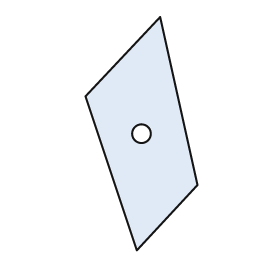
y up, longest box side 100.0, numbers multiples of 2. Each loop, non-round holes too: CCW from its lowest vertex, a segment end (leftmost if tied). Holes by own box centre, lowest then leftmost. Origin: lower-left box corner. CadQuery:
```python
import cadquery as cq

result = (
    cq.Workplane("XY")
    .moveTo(22.0, 0.0)
    .lineTo(48.0, 28.0)
    .lineTo(32.0, 100.0)
    .lineTo(0.0, 66.0)
    .close()
    .moveTo(24.0, 50.0)
    .circle(4.0)
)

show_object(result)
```